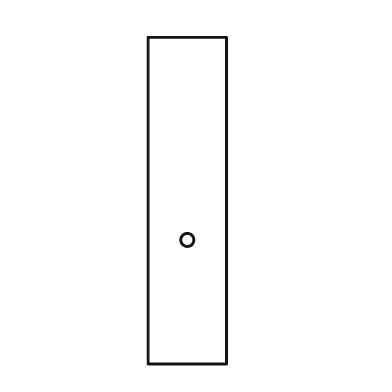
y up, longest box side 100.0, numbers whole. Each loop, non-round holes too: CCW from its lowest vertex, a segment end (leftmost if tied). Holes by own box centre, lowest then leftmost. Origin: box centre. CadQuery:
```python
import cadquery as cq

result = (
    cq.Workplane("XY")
    .moveTo(-12.0, -50.0)
    .lineTo(12.0, -50.0)
    .lineTo(12.0, 50.0)
    .lineTo(-12.0, 50.0)
    .close()
    .moveTo(0.0, -12.0)
    .circle(2.0)
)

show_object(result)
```